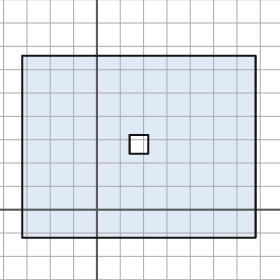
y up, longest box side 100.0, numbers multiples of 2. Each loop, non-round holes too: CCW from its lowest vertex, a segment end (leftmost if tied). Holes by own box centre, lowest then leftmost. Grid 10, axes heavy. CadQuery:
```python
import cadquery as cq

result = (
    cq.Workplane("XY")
    .moveTo(-32.0, -12.0)
    .lineTo(68.0, -12.0)
    .lineTo(68.0, 66.0)
    .lineTo(-32.0, 66.0)
    .close()
    .moveTo(14.0, 24.0)
    .lineTo(22.0, 24.0)
    .lineTo(22.0, 32.0)
    .lineTo(14.0, 32.0)
    .close()
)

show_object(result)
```